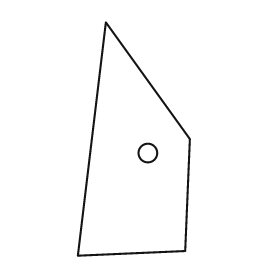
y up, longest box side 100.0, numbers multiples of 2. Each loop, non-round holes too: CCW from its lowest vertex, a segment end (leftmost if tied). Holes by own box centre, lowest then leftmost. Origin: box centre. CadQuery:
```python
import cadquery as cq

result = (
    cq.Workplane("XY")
    .moveTo(-24.0, -50.0)
    .lineTo(22.0, -48.0)
    .lineTo(24.0, 0.0)
    .lineTo(-12.0, 50.0)
    .close()
    .moveTo(6.0, -6.0)
    .circle(4.0)
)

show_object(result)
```